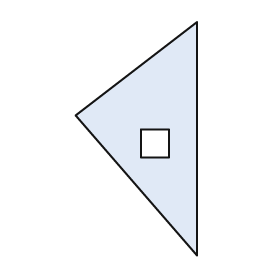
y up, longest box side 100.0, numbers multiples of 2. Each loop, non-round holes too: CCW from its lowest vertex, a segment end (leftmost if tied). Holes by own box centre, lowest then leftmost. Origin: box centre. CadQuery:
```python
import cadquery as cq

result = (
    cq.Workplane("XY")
    .moveTo(26.0, -50.0)
    .lineTo(26.0, 50.0)
    .lineTo(-26.0, 10.0)
    .close()
    .moveTo(2.0, -8.0)
    .lineTo(14.0, -8.0)
    .lineTo(14.0, 4.0)
    .lineTo(2.0, 4.0)
    .close()
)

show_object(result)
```